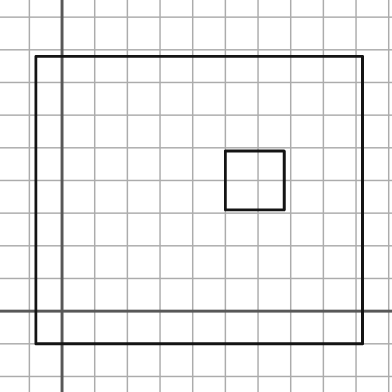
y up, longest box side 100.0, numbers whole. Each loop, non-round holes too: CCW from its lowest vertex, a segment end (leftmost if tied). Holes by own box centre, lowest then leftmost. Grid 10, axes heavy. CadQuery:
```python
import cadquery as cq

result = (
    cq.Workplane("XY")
    .moveTo(-8.0, -10.0)
    .lineTo(92.0, -10.0)
    .lineTo(92.0, 78.0)
    .lineTo(-8.0, 78.0)
    .close()
    .moveTo(50.0, 31.0)
    .lineTo(68.0, 31.0)
    .lineTo(68.0, 49.0)
    .lineTo(50.0, 49.0)
    .close()
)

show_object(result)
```